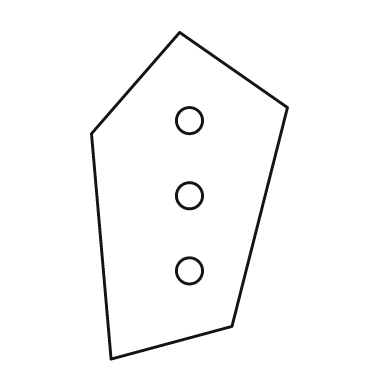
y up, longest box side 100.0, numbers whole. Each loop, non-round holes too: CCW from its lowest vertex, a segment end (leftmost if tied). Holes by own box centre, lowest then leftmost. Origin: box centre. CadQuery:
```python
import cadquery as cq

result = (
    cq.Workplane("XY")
    .moveTo(-24.0, -50.0)
    .lineTo(13.0, -40.0)
    .lineTo(30.0, 27.0)
    .lineTo(-3.0, 50.0)
    .lineTo(-30.0, 19.0)
    .close()
    .moveTo(0.0, -23.0)
    .circle(4.0)
    .moveTo(0.0, 0.0)
    .circle(4.0)
    .moveTo(0.0, 23.0)
    .circle(4.0)
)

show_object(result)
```